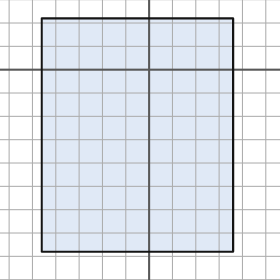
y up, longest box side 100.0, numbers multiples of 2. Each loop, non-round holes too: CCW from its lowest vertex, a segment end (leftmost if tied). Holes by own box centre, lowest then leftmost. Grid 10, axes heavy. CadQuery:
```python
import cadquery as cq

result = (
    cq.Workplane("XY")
    .moveTo(-46.0, -78.0)
    .lineTo(36.0, -78.0)
    .lineTo(36.0, 22.0)
    .lineTo(-46.0, 22.0)
    .close()
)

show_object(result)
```